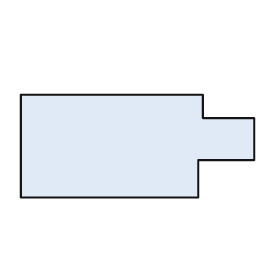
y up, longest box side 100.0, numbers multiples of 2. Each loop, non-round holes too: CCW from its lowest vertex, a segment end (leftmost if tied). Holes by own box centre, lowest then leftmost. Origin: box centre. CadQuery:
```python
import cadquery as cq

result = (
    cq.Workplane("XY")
    .moveTo(-50.0, -22.0)
    .lineTo(26.0, -22.0)
    .lineTo(26.0, -6.0)
    .lineTo(50.0, -6.0)
    .lineTo(50.0, 12.0)
    .lineTo(28.0, 12.0)
    .lineTo(28.0, 22.0)
    .lineTo(-50.0, 22.0)
    .close()
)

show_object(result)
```